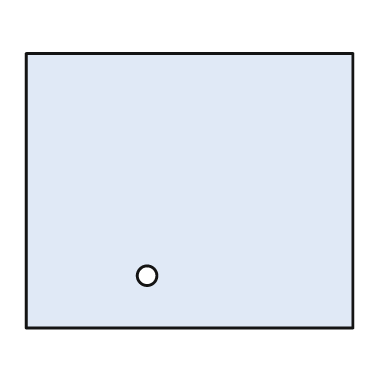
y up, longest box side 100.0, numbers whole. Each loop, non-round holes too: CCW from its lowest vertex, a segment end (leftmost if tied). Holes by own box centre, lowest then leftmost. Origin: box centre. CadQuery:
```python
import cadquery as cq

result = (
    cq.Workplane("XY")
    .moveTo(-50.0, -42.0)
    .lineTo(50.0, -42.0)
    .lineTo(50.0, 42.0)
    .lineTo(-50.0, 42.0)
    .close()
    .moveTo(-13.0, -26.0)
    .circle(3.0)
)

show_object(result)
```